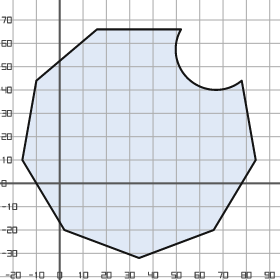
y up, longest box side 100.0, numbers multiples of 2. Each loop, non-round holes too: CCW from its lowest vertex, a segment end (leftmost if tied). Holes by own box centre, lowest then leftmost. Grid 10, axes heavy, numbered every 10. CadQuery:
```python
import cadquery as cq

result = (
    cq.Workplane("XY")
    .moveTo(34.0, -32.0)
    .lineTo(66.0, -20.0)
    .lineTo(84.0, 10.0)
    .lineTo(78.0, 44.0)
    .threePointArc((56.0, 44.0), (52.0, 66.0))
    .lineTo(16.0, 66.0)
    .lineTo(-10.0, 44.0)
    .lineTo(-16.0, 10.0)
    .lineTo(2.0, -20.0)
    .close()
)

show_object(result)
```